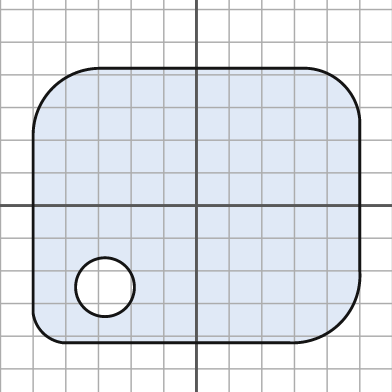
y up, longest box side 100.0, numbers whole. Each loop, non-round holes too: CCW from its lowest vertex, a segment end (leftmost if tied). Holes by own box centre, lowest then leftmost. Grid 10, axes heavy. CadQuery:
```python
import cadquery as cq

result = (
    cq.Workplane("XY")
    .moveTo(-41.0, -42.0)
    .lineTo(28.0, -42.0)
    .threePointArc((44.0, -36.0), (50.0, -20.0))
    .lineTo(50.0, 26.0)
    .threePointArc((45.0, 37.0), (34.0, 42.0))
    .lineTo(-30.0, 42.0)
    .threePointArc((-44.0, 36.0), (-50.0, 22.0))
    .lineTo(-50.0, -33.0)
    .threePointArc((-47.0, -39.0), (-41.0, -42.0))
    .close()
    .moveTo(-28.0, -25.0)
    .circle(9.0)
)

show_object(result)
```